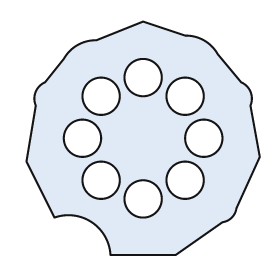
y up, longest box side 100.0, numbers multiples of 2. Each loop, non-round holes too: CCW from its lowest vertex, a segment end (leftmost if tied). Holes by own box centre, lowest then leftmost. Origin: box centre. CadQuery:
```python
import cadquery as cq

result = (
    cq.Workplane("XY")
    .moveTo(-14.0, -50.0)
    .lineTo(14.0, -50.0)
    .lineTo(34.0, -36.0)
    .threePointArc((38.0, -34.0), (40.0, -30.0))
    .lineTo(50.0, -8.0)
    .lineTo(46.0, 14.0)
    .threePointArc((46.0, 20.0), (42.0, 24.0))
    .lineTo(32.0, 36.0)
    .threePointArc((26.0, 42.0), (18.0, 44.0))
    .lineTo(0.0, 50.0)
    .lineTo(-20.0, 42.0)
    .threePointArc((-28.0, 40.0), (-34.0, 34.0))
    .lineTo(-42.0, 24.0)
    .threePointArc((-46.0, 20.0), (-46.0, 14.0))
    .lineTo(-50.0, -10.0)
    .lineTo(-38.0, -34.0)
    .threePointArc((-22.0, -36.0), (-14.0, -50.0))
    .close()
    .moveTo(0.0, -26.0)
    .circle(8.0)
    .moveTo(-18.0, -18.0)
    .circle(8.0)
    .moveTo(18.0, -18.0)
    .circle(8.0)
    .moveTo(-26.0, 0.0)
    .circle(8.0)
    .moveTo(26.0, 0.0)
    .circle(8.0)
    .moveTo(-18.0, 18.0)
    .circle(8.0)
    .moveTo(18.0, 18.0)
    .circle(8.0)
    .moveTo(0.0, 26.0)
    .circle(8.0)
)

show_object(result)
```